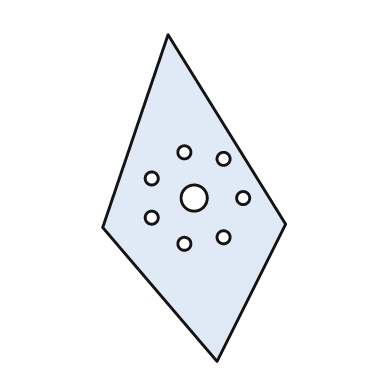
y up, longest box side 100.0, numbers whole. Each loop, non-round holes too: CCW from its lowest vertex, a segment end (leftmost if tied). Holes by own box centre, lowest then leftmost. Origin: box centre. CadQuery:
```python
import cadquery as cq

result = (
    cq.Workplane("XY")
    .moveTo(7.0, -50.0)
    .lineTo(28.0, -8.0)
    .lineTo(-8.0, 50.0)
    .lineTo(-28.0, -9.0)
    .close()
    .moveTo(-3.0, -14.0)
    .circle(2.0)
    .moveTo(9.0, -12.0)
    .circle(2.0)
    .moveTo(-13.0, -6.0)
    .circle(2.0)
    .moveTo(0.0, 0.0)
    .circle(4.0)
    .moveTo(15.0, 0.0)
    .circle(2.0)
    .moveTo(-13.0, 6.0)
    .circle(2.0)
    .moveTo(9.0, 12.0)
    .circle(2.0)
    .moveTo(-3.0, 14.0)
    .circle(2.0)
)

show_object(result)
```